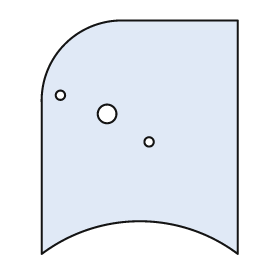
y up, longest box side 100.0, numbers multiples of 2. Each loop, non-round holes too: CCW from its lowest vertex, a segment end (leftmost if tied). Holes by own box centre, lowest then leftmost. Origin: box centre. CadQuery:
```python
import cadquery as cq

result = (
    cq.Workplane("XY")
    .moveTo(-42.0, -50.0)
    .threePointArc((0.0, -36.0), (42.0, -50.0))
    .lineTo(42.0, 50.0)
    .lineTo(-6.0, 50.0)
    .threePointArc((-32.0, 40.0), (-42.0, 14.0))
    .close()
    .moveTo(4.0, -2.0)
    .circle(2.0)
    .moveTo(-14.0, 10.0)
    .circle(4.0)
    .moveTo(-34.0, 18.0)
    .circle(2.0)
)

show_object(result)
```